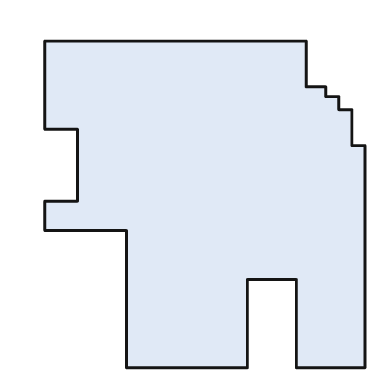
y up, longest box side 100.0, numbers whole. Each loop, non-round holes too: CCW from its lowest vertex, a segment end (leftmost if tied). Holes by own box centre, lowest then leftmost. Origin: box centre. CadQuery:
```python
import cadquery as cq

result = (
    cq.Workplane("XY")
    .moveTo(-24.0, -50.0)
    .lineTo(13.0, -50.0)
    .lineTo(13.0, -23.0)
    .lineTo(28.0, -23.0)
    .lineTo(28.0, -50.0)
    .lineTo(49.0, -50.0)
    .lineTo(49.0, 18.0)
    .lineTo(45.0, 18.0)
    .lineTo(45.0, 29.0)
    .lineTo(41.0, 29.0)
    .lineTo(41.0, 33.0)
    .lineTo(37.0, 33.0)
    .lineTo(37.0, 36.0)
    .lineTo(31.0, 36.0)
    .lineTo(31.0, 50.0)
    .lineTo(-49.0, 50.0)
    .lineTo(-49.0, 23.0)
    .lineTo(-39.0, 23.0)
    .lineTo(-39.0, 1.0)
    .lineTo(-49.0, 1.0)
    .lineTo(-49.0, -8.0)
    .lineTo(-24.0, -8.0)
    .close()
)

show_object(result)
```